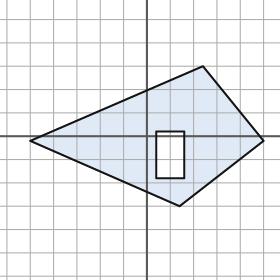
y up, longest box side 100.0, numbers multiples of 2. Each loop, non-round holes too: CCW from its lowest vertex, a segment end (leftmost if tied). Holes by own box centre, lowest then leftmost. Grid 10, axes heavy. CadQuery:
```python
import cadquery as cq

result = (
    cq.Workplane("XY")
    .moveTo(14.0, -30.0)
    .lineTo(50.0, -2.0)
    .lineTo(24.0, 30.0)
    .lineTo(-50.0, -2.0)
    .close()
    .moveTo(4.0, -18.0)
    .lineTo(16.0, -18.0)
    .lineTo(16.0, 2.0)
    .lineTo(4.0, 2.0)
    .close()
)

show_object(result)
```